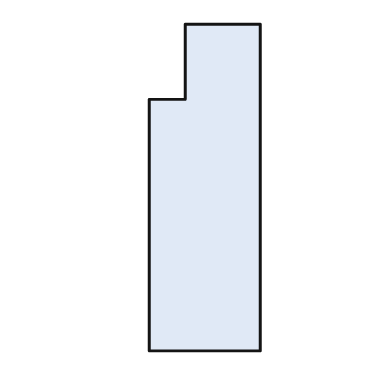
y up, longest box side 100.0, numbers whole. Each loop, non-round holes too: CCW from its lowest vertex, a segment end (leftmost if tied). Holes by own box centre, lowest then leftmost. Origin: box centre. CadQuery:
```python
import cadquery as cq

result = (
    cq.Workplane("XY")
    .moveTo(-17.0, -50.0)
    .lineTo(17.0, -50.0)
    .lineTo(17.0, 50.0)
    .lineTo(-6.0, 50.0)
    .lineTo(-6.0, 27.0)
    .lineTo(-17.0, 27.0)
    .close()
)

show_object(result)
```